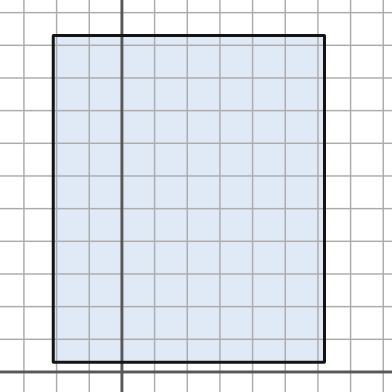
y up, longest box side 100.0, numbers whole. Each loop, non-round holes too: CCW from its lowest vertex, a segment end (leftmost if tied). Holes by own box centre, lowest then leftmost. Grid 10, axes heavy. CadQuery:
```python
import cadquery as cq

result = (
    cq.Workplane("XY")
    .moveTo(-21.0, 3.0)
    .lineTo(62.0, 3.0)
    .lineTo(62.0, 103.0)
    .lineTo(-21.0, 103.0)
    .close()
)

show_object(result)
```